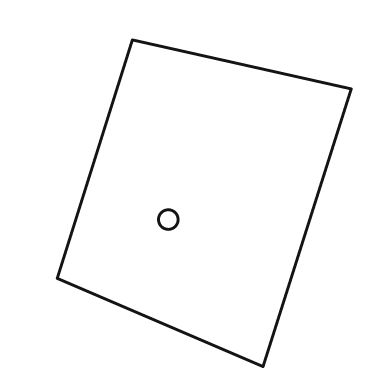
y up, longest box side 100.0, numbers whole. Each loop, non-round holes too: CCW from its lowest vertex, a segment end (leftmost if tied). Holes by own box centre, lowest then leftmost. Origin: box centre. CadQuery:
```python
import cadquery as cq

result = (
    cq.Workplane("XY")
    .moveTo(18.0, -50.0)
    .lineTo(45.0, 35.0)
    .lineTo(-22.0, 50.0)
    .lineTo(-45.0, -23.0)
    .close()
    .moveTo(-11.0, -5.0)
    .circle(3.0)
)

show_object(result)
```